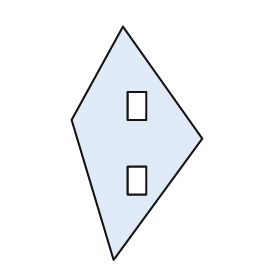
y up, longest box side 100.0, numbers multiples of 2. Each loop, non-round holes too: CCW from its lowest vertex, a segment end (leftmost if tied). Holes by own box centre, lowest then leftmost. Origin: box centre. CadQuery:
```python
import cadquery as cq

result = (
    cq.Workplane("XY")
    .moveTo(-10.0, -50.0)
    .lineTo(28.0, 2.0)
    .lineTo(-6.0, 50.0)
    .lineTo(-28.0, 10.0)
    .close()
    .moveTo(-4.0, -22.0)
    .lineTo(4.0, -22.0)
    .lineTo(4.0, -10.0)
    .lineTo(-4.0, -10.0)
    .close()
    .moveTo(-4.0, 10.0)
    .lineTo(4.0, 10.0)
    .lineTo(4.0, 22.0)
    .lineTo(-4.0, 22.0)
    .close()
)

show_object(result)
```